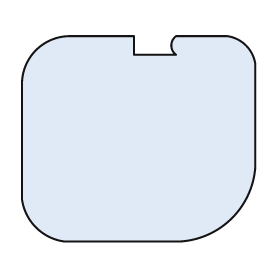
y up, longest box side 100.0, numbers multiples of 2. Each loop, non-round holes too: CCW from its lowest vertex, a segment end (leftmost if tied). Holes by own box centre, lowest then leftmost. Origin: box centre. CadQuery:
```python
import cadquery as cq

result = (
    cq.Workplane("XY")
    .moveTo(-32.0, -44.0)
    .lineTo(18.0, -44.0)
    .threePointArc((40.0, -34.0), (50.0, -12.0))
    .lineTo(50.0, 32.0)
    .threePointArc((46.0, 40.0), (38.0, 44.0))
    .lineTo(16.0, 44.0)
    .threePointArc((14.0, 40.0), (16.0, 36.0))
    .lineTo(-2.0, 36.0)
    .lineTo(-2.0, 44.0)
    .lineTo(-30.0, 44.0)
    .threePointArc((-44.0, 38.0), (-50.0, 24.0))
    .lineTo(-50.0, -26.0)
    .threePointArc((-44.0, -38.0), (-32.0, -44.0))
    .close()
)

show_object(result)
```